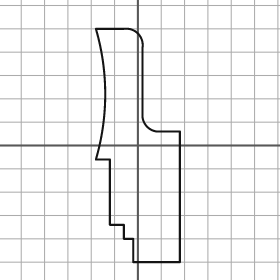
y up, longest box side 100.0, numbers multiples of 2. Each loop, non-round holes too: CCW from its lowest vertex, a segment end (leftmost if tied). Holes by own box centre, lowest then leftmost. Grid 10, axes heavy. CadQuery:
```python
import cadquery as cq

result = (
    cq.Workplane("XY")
    .moveTo(-2.0, -50.0)
    .lineTo(18.0, -50.0)
    .lineTo(18.0, 6.0)
    .lineTo(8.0, 6.0)
    .threePointArc((4.0, 8.0), (2.0, 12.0))
    .lineTo(2.0, 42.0)
    .threePointArc((0.0, 48.0), (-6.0, 50.0))
    .lineTo(-18.0, 50.0)
    .threePointArc((-14.0, 22.0), (-18.0, -6.0))
    .lineTo(-12.0, -6.0)
    .lineTo(-12.0, -34.0)
    .lineTo(-6.0, -34.0)
    .lineTo(-6.0, -40.0)
    .lineTo(-2.0, -40.0)
    .close()
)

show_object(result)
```